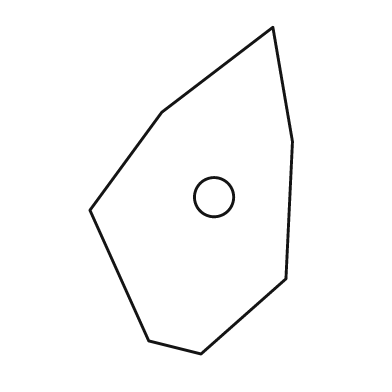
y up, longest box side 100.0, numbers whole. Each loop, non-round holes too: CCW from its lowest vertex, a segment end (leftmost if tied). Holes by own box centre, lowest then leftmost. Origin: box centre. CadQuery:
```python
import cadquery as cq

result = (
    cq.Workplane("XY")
    .moveTo(3.0, -50.0)
    .lineTo(29.0, -27.0)
    .lineTo(31.0, 15.0)
    .lineTo(25.0, 50.0)
    .lineTo(-9.0, 24.0)
    .lineTo(-31.0, -6.0)
    .lineTo(-13.0, -46.0)
    .close()
    .moveTo(7.0, -2.0)
    .circle(6.0)
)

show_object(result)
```